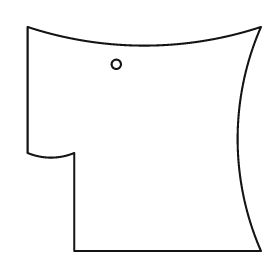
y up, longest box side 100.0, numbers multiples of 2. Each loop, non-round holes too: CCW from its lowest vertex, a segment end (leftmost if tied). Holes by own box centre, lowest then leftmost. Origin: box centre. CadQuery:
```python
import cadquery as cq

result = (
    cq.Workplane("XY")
    .moveTo(-30.0, -48.0)
    .lineTo(50.0, -48.0)
    .threePointArc((40.0, 0.0), (50.0, 48.0))
    .threePointArc((0.0, 40.0), (-50.0, 48.0))
    .lineTo(-50.0, -6.0)
    .threePointArc((-40.0, -8.0), (-30.0, -6.0))
    .close()
    .moveTo(-12.0, 32.0)
    .circle(2.0)
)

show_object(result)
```